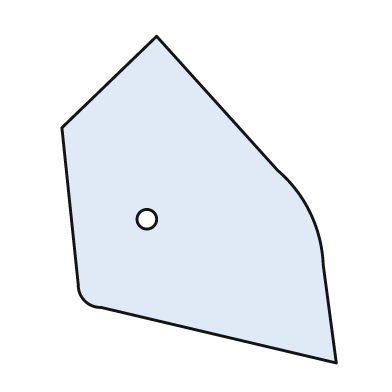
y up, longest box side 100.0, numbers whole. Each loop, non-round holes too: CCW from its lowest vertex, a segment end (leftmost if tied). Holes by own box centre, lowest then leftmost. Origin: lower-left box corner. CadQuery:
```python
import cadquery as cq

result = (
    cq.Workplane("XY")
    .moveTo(84.0, 0.0)
    .lineTo(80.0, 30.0)
    .threePointArc((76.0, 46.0), (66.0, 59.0))
    .lineTo(29.0, 100.0)
    .lineTo(0.0, 72.0)
    .lineTo(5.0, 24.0)
    .threePointArc((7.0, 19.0), (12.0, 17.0))
    .close()
    .moveTo(26.0, 44.0)
    .circle(3.0)
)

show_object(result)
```